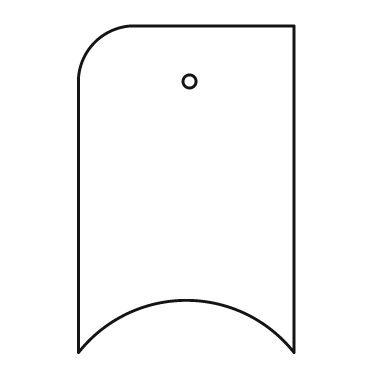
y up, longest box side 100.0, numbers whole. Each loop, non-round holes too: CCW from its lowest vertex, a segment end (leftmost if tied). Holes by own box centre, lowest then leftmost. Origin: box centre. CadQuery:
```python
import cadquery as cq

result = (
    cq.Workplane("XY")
    .moveTo(-33.0, -50.0)
    .threePointArc((0.0, -34.0), (33.0, -50.0))
    .lineTo(33.0, 50.0)
    .lineTo(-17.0, 50.0)
    .threePointArc((-28.0, 45.0), (-33.0, 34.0))
    .close()
    .moveTo(1.0, 33.0)
    .circle(2.0)
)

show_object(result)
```